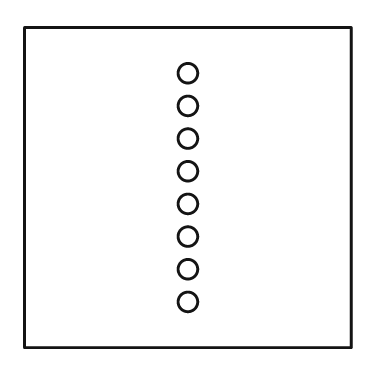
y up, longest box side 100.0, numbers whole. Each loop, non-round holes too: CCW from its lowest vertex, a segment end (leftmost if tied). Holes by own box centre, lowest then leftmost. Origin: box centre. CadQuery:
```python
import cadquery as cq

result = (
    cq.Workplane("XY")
    .moveTo(-50.0, -49.0)
    .lineTo(50.0, -49.0)
    .lineTo(50.0, 49.0)
    .lineTo(-50.0, 49.0)
    .close()
    .moveTo(0.0, -35.0)
    .circle(3.0)
    .moveTo(0.0, -25.0)
    .circle(3.0)
    .moveTo(0.0, -15.0)
    .circle(3.0)
    .moveTo(0.0, -5.0)
    .circle(3.0)
    .moveTo(0.0, 5.0)
    .circle(3.0)
    .moveTo(0.0, 15.0)
    .circle(3.0)
    .moveTo(0.0, 25.0)
    .circle(3.0)
    .moveTo(0.0, 35.0)
    .circle(3.0)
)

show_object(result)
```